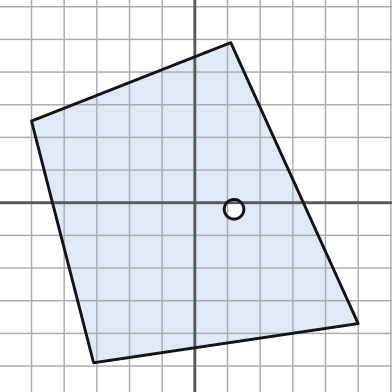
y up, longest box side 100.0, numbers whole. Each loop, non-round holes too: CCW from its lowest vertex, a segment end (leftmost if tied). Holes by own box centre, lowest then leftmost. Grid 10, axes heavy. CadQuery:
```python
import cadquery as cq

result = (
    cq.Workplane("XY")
    .moveTo(-31.0, -49.0)
    .lineTo(50.0, -37.0)
    .lineTo(11.0, 49.0)
    .lineTo(-50.0, 25.0)
    .close()
    .moveTo(12.0, -2.0)
    .circle(3.0)
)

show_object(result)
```